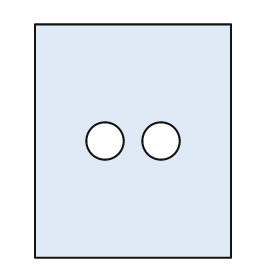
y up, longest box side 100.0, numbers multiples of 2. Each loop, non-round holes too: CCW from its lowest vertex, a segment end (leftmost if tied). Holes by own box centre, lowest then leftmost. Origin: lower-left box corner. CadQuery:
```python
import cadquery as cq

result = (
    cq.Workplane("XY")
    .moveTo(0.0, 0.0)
    .lineTo(84.0, 0.0)
    .lineTo(84.0, 100.0)
    .lineTo(0.0, 100.0)
    .close()
    .moveTo(30.0, 50.0)
    .circle(8.0)
    .moveTo(54.0, 50.0)
    .circle(8.0)
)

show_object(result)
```